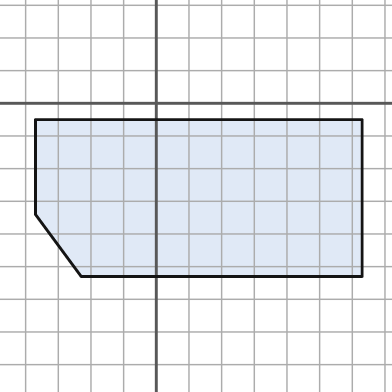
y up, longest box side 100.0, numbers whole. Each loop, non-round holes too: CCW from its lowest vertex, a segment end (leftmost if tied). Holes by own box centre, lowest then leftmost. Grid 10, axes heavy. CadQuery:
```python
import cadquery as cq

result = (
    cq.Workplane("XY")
    .moveTo(-23.0, -53.0)
    .lineTo(63.0, -53.0)
    .lineTo(63.0, -5.0)
    .lineTo(-37.0, -5.0)
    .lineTo(-37.0, -34.0)
    .close()
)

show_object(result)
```